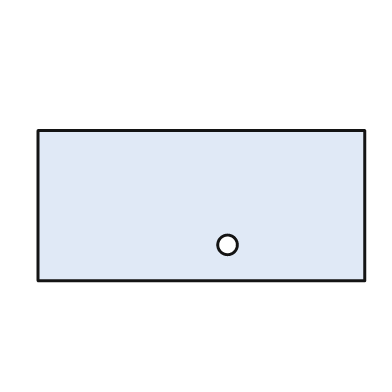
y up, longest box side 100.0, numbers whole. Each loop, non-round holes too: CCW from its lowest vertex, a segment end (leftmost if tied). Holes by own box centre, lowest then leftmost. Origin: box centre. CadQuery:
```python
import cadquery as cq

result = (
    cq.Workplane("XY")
    .moveTo(-50.0, -23.0)
    .lineTo(50.0, -23.0)
    .lineTo(50.0, 23.0)
    .lineTo(-50.0, 23.0)
    .close()
    .moveTo(8.0, -12.0)
    .circle(3.0)
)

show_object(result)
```